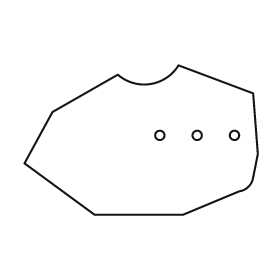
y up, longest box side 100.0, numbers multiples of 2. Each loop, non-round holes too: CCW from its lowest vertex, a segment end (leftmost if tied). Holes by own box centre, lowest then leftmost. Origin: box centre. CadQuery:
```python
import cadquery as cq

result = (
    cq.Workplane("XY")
    .moveTo(-20.0, -32.0)
    .lineTo(18.0, -32.0)
    .lineTo(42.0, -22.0)
    .threePointArc((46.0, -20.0), (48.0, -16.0))
    .lineTo(50.0, -6.0)
    .lineTo(48.0, 20.0)
    .lineTo(16.0, 32.0)
    .threePointArc((4.0, 24.0), (-10.0, 28.0))
    .lineTo(-38.0, 12.0)
    .lineTo(-50.0, -10.0)
    .close()
    .moveTo(8.0, 2.0)
    .circle(2.0)
    .moveTo(24.0, 2.0)
    .circle(2.0)
    .moveTo(40.0, 2.0)
    .circle(2.0)
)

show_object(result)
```